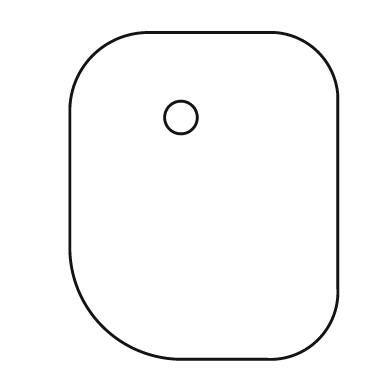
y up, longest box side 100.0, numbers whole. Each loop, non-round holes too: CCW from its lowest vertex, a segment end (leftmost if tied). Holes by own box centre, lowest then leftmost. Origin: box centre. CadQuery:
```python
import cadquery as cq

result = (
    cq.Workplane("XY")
    .moveTo(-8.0, -50.0)
    .lineTo(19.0, -50.0)
    .threePointArc((35.0, -44.0), (41.0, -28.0))
    .lineTo(41.0, 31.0)
    .threePointArc((35.0, 44.0), (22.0, 50.0))
    .lineTo(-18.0, 50.0)
    .threePointArc((-34.0, 43.0), (-41.0, 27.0))
    .lineTo(-41.0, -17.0)
    .threePointArc((-31.0, -40.0), (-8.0, -50.0))
    .close()
    .moveTo(-7.0, 24.0)
    .circle(5.0)
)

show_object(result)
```